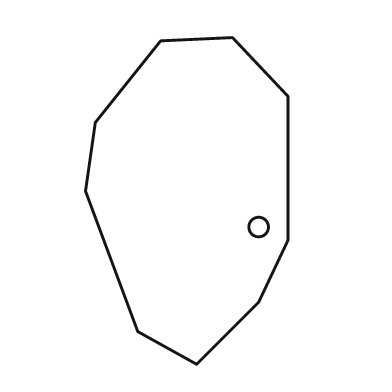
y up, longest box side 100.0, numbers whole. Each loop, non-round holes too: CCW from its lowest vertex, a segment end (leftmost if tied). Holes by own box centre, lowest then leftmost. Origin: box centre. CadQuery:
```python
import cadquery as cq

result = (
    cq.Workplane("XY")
    .moveTo(3.0, -50.0)
    .lineTo(22.0, -31.0)
    .lineTo(31.0, -12.0)
    .lineTo(31.0, 32.0)
    .lineTo(14.0, 50.0)
    .lineTo(-8.0, 49.0)
    .lineTo(-28.0, 24.0)
    .lineTo(-31.0, 3.0)
    .lineTo(-15.0, -40.0)
    .close()
    .moveTo(22.0, -8.0)
    .circle(3.0)
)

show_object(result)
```